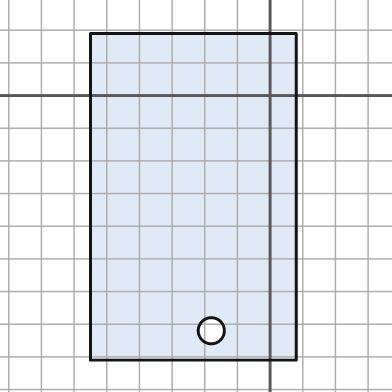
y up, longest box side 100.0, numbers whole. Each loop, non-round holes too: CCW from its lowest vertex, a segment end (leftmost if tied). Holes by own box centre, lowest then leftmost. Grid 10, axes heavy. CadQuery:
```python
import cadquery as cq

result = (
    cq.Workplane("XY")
    .moveTo(-55.0, -81.0)
    .lineTo(8.0, -81.0)
    .lineTo(8.0, 19.0)
    .lineTo(-55.0, 19.0)
    .close()
    .moveTo(-18.0, -72.0)
    .circle(4.0)
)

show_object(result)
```